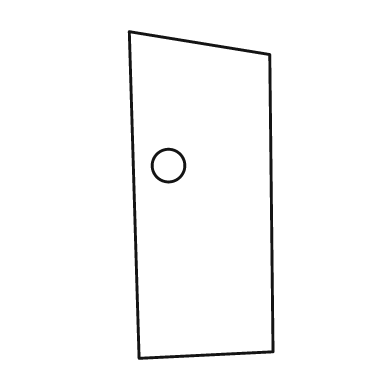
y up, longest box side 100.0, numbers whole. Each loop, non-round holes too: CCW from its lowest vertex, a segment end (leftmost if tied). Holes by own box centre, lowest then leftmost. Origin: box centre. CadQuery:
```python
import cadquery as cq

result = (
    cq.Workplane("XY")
    .moveTo(-19.0, -50.0)
    .lineTo(22.0, -48.0)
    .lineTo(21.0, 43.0)
    .lineTo(-22.0, 50.0)
    .close()
    .moveTo(-10.0, 9.0)
    .circle(5.0)
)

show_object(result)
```